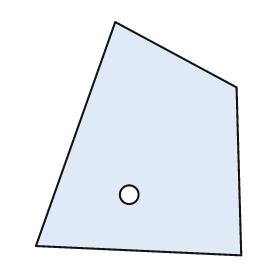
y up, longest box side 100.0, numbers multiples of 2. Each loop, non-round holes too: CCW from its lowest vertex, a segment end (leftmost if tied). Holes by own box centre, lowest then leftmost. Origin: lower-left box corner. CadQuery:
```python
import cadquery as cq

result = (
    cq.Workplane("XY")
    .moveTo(88.0, 0.0)
    .lineTo(86.0, 72.0)
    .lineTo(34.0, 100.0)
    .lineTo(0.0, 4.0)
    .close()
    .moveTo(40.0, 26.0)
    .circle(4.0)
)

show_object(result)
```